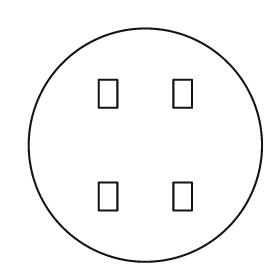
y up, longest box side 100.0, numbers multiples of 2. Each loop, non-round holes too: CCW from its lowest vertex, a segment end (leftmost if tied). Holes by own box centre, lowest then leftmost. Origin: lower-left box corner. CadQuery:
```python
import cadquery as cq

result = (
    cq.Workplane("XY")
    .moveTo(50.0, 50.0)
    .circle(50.0)
    .moveTo(30.0, 22.0)
    .lineTo(38.0, 22.0)
    .lineTo(38.0, 34.0)
    .lineTo(30.0, 34.0)
    .close()
    .moveTo(62.0, 22.0)
    .lineTo(70.0, 22.0)
    .lineTo(70.0, 34.0)
    .lineTo(62.0, 34.0)
    .close()
    .moveTo(30.0, 66.0)
    .lineTo(38.0, 66.0)
    .lineTo(38.0, 78.0)
    .lineTo(30.0, 78.0)
    .close()
    .moveTo(62.0, 66.0)
    .lineTo(70.0, 66.0)
    .lineTo(70.0, 78.0)
    .lineTo(62.0, 78.0)
    .close()
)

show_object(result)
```